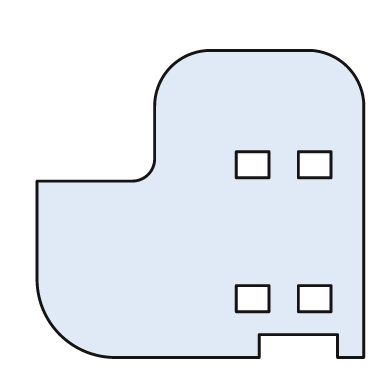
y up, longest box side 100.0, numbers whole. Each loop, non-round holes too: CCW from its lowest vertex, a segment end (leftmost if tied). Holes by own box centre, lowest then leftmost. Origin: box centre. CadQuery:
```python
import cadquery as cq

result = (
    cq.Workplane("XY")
    .moveTo(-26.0, -47.0)
    .lineTo(18.0, -47.0)
    .lineTo(18.0, -40.0)
    .lineTo(42.0, -40.0)
    .lineTo(42.0, -47.0)
    .lineTo(50.0, -47.0)
    .lineTo(50.0, 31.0)
    .threePointArc((45.0, 42.0), (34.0, 47.0))
    .lineTo(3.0, 47.0)
    .threePointArc((-9.0, 42.0), (-14.0, 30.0))
    .lineTo(-14.0, 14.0)
    .threePointArc((-16.0, 9.0), (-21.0, 7.0))
    .lineTo(-50.0, 7.0)
    .lineTo(-50.0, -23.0)
    .threePointArc((-43.0, -40.0), (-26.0, -47.0))
    .close()
    .moveTo(11.0, -33.0)
    .lineTo(21.0, -33.0)
    .lineTo(21.0, -25.0)
    .lineTo(11.0, -25.0)
    .close()
    .moveTo(30.0, -33.0)
    .lineTo(40.0, -33.0)
    .lineTo(40.0, -25.0)
    .lineTo(30.0, -25.0)
    .close()
    .moveTo(11.0, 8.0)
    .lineTo(21.0, 8.0)
    .lineTo(21.0, 16.0)
    .lineTo(11.0, 16.0)
    .close()
    .moveTo(30.0, 8.0)
    .lineTo(40.0, 8.0)
    .lineTo(40.0, 16.0)
    .lineTo(30.0, 16.0)
    .close()
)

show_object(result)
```